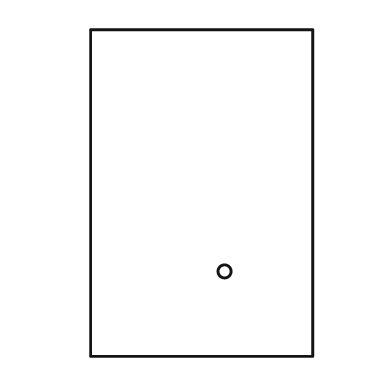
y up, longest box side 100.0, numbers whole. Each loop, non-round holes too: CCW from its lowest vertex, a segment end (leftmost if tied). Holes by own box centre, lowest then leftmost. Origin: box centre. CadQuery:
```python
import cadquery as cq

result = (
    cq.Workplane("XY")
    .moveTo(-34.0, -50.0)
    .lineTo(34.0, -50.0)
    .lineTo(34.0, 50.0)
    .lineTo(-34.0, 50.0)
    .close()
    .moveTo(7.0, -24.0)
    .circle(2.0)
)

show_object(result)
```